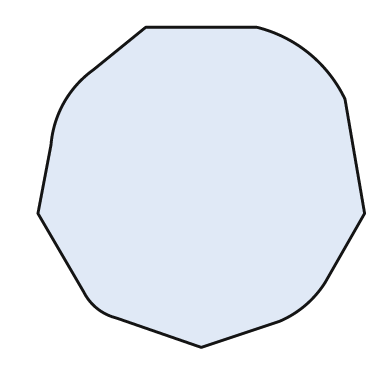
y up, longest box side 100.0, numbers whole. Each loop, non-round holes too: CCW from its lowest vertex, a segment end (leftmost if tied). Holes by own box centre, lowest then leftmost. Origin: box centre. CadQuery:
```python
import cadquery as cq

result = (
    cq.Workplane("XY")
    .moveTo(0.0, -49.0)
    .lineTo(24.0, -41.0)
    .threePointArc((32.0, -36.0), (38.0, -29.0))
    .lineTo(50.0, -8.0)
    .lineTo(44.0, 27.0)
    .threePointArc((33.0, 41.0), (17.0, 49.0))
    .lineTo(-17.0, 49.0)
    .lineTo(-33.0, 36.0)
    .threePointArc((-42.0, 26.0), (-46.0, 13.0))
    .lineTo(-50.0, -8.0)
    .lineTo(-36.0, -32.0)
    .threePointArc((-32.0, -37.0), (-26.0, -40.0))
    .close()
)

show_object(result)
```